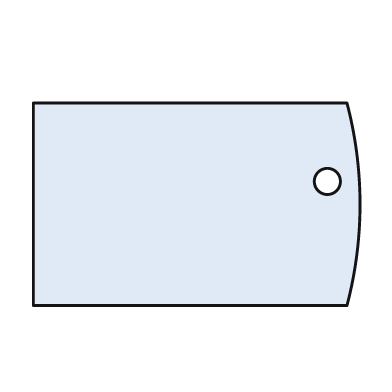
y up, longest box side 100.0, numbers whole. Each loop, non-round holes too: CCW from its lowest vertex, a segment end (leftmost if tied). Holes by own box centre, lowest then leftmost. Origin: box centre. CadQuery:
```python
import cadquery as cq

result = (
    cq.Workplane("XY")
    .moveTo(-50.0, -31.0)
    .lineTo(46.0, -31.0)
    .threePointArc((50.0, 0.0), (46.0, 31.0))
    .lineTo(-50.0, 31.0)
    .close()
    .moveTo(40.0, 7.0)
    .circle(4.0)
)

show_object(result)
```